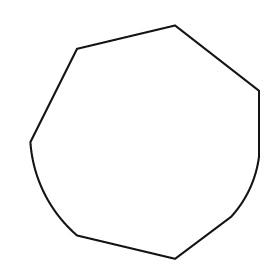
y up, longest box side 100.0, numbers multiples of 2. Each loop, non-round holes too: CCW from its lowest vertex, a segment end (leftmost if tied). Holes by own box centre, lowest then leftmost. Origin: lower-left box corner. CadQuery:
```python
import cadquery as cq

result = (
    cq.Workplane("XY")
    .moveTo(62.0, 0.0)
    .lineTo(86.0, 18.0)
    .threePointArc((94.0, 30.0), (98.0, 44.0))
    .lineTo(98.0, 72.0)
    .lineTo(62.0, 100.0)
    .lineTo(20.0, 90.0)
    .lineTo(0.0, 50.0)
    .threePointArc((6.0, 28.0), (20.0, 10.0))
    .close()
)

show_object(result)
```